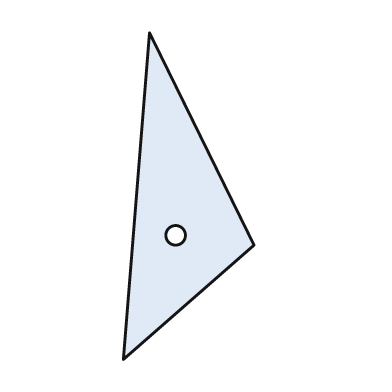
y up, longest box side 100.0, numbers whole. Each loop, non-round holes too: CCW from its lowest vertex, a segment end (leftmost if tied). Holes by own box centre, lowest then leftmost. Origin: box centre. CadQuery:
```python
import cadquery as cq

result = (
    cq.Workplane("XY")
    .moveTo(-20.0, -50.0)
    .lineTo(20.0, -15.0)
    .lineTo(-12.0, 50.0)
    .close()
    .moveTo(-4.0, -12.0)
    .circle(3.0)
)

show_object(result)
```